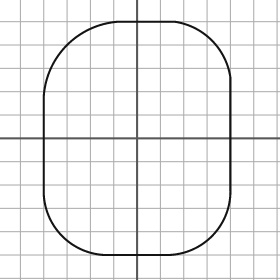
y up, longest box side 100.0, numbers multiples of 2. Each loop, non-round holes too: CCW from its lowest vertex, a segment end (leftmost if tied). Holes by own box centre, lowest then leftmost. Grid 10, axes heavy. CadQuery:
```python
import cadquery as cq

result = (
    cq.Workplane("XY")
    .moveTo(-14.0, -50.0)
    .lineTo(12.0, -50.0)
    .threePointArc((32.0, -42.0), (40.0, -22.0))
    .lineTo(40.0, 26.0)
    .threePointArc((32.0, 42.0), (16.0, 50.0))
    .lineTo(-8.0, 50.0)
    .threePointArc((-30.0, 40.0), (-40.0, 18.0))
    .lineTo(-40.0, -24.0)
    .threePointArc((-32.0, -42.0), (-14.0, -50.0))
    .close()
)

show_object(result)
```